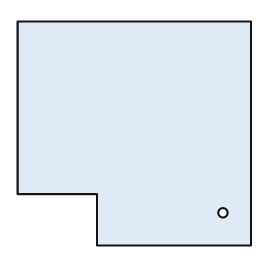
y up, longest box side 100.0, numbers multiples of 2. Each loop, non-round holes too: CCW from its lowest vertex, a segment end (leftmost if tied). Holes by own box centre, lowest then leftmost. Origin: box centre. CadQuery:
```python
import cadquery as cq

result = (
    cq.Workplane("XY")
    .moveTo(-16.0, -48.0)
    .lineTo(50.0, -48.0)
    .lineTo(50.0, 48.0)
    .lineTo(-50.0, 48.0)
    .lineTo(-50.0, -26.0)
    .lineTo(-16.0, -26.0)
    .close()
    .moveTo(38.0, -34.0)
    .circle(2.0)
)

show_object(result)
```